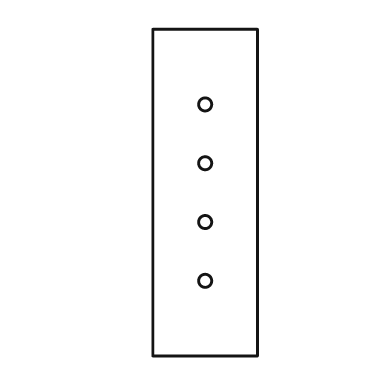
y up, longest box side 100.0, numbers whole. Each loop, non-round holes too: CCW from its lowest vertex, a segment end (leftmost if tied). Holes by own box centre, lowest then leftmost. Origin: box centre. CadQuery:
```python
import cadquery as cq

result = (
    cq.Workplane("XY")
    .moveTo(-16.0, -50.0)
    .lineTo(16.0, -50.0)
    .lineTo(16.0, 50.0)
    .lineTo(-16.0, 50.0)
    .close()
    .moveTo(0.0, -27.0)
    .circle(2.0)
    .moveTo(0.0, -9.0)
    .circle(2.0)
    .moveTo(0.0, 9.0)
    .circle(2.0)
    .moveTo(0.0, 27.0)
    .circle(2.0)
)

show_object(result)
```